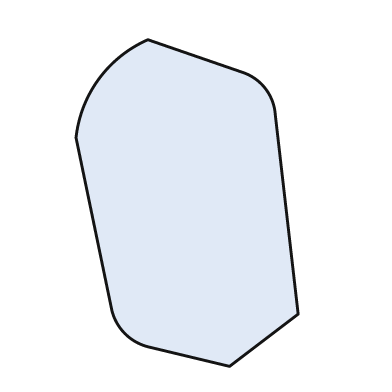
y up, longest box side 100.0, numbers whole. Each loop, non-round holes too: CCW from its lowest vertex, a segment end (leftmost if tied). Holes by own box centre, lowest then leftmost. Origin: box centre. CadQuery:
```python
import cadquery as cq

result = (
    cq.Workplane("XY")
    .moveTo(13.0, -50.0)
    .lineTo(34.0, -34.0)
    .lineTo(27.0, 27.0)
    .threePointArc((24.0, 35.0), (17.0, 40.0))
    .lineTo(-12.0, 50.0)
    .threePointArc((-27.0, 38.0), (-34.0, 20.0))
    .lineTo(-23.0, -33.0)
    .threePointArc((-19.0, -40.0), (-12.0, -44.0))
    .close()
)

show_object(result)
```